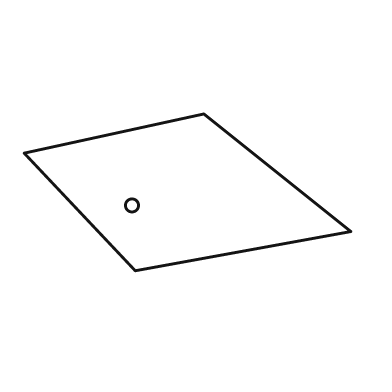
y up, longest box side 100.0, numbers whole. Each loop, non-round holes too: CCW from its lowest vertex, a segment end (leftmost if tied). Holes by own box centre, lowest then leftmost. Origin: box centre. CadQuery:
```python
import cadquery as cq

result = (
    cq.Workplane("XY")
    .moveTo(-16.0, -24.0)
    .lineTo(50.0, -12.0)
    .lineTo(5.0, 24.0)
    .lineTo(-50.0, 12.0)
    .close()
    .moveTo(-17.0, -4.0)
    .circle(2.0)
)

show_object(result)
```